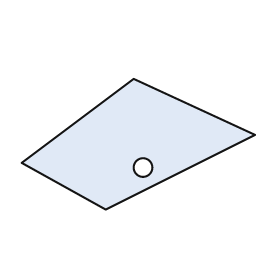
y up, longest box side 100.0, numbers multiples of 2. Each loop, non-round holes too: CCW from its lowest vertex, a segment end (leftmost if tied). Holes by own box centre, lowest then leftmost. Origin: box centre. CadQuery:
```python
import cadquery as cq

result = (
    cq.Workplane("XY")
    .moveTo(-14.0, -28.0)
    .lineTo(50.0, 4.0)
    .lineTo(-2.0, 28.0)
    .lineTo(-50.0, -8.0)
    .close()
    .moveTo(2.0, -10.0)
    .circle(4.0)
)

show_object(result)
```